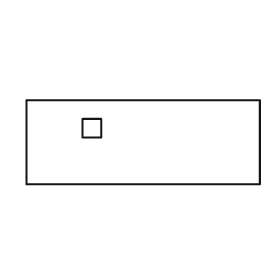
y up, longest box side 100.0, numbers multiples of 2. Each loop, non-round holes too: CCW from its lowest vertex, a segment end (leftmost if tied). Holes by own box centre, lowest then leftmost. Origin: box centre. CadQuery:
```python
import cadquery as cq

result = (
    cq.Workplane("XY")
    .moveTo(-50.0, -18.0)
    .lineTo(50.0, -18.0)
    .lineTo(50.0, 18.0)
    .lineTo(-50.0, 18.0)
    .close()
    .moveTo(-26.0, 2.0)
    .lineTo(-18.0, 2.0)
    .lineTo(-18.0, 10.0)
    .lineTo(-26.0, 10.0)
    .close()
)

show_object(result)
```